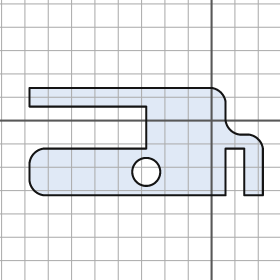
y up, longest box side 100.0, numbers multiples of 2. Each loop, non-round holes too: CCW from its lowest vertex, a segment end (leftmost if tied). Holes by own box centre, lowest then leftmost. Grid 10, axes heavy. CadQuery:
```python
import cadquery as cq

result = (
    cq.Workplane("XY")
    .moveTo(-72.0, -32.0)
    .lineTo(6.0, -32.0)
    .lineTo(6.0, -12.0)
    .lineTo(14.0, -12.0)
    .lineTo(14.0, -32.0)
    .lineTo(22.0, -32.0)
    .lineTo(22.0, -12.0)
    .threePointArc((20.0, -8.0), (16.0, -6.0))
    .lineTo(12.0, -6.0)
    .threePointArc((8.0, -4.0), (6.0, 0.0))
    .lineTo(6.0, 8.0)
    .threePointArc((4.0, 12.0), (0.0, 14.0))
    .lineTo(-78.0, 14.0)
    .lineTo(-78.0, 6.0)
    .lineTo(-28.0, 6.0)
    .lineTo(-28.0, -12.0)
    .lineTo(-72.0, -12.0)
    .threePointArc((-76.0, -14.0), (-78.0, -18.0))
    .lineTo(-78.0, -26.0)
    .threePointArc((-76.0, -30.0), (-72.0, -32.0))
    .close()
    .moveTo(-28.0, -22.0)
    .circle(6.0)
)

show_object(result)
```